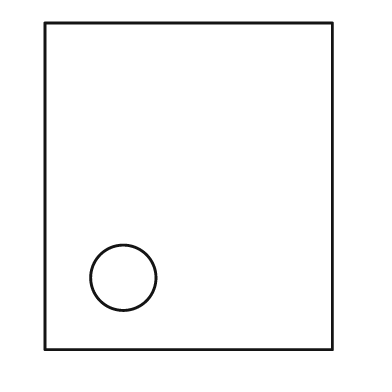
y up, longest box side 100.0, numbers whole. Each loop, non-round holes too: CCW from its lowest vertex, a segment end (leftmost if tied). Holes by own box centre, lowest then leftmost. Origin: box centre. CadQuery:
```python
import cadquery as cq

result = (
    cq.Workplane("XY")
    .moveTo(-44.0, -50.0)
    .lineTo(44.0, -50.0)
    .lineTo(44.0, 50.0)
    .lineTo(-44.0, 50.0)
    .close()
    .moveTo(-20.0, -28.0)
    .circle(10.0)
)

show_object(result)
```